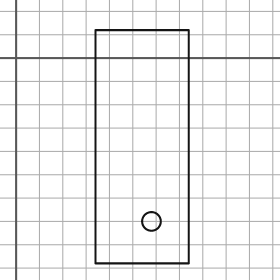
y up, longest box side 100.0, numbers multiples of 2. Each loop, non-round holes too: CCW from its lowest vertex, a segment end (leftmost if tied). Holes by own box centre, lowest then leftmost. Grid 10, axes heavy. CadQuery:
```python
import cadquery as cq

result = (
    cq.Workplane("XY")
    .moveTo(34.0, -88.0)
    .lineTo(74.0, -88.0)
    .lineTo(74.0, 12.0)
    .lineTo(34.0, 12.0)
    .close()
    .moveTo(58.0, -70.0)
    .circle(4.0)
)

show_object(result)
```